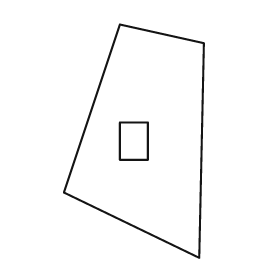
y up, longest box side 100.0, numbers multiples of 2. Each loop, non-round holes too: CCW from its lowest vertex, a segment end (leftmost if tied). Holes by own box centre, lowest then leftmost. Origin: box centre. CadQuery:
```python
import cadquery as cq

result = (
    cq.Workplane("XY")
    .moveTo(28.0, -50.0)
    .lineTo(30.0, 42.0)
    .lineTo(-6.0, 50.0)
    .lineTo(-30.0, -22.0)
    .close()
    .moveTo(-6.0, -8.0)
    .lineTo(6.0, -8.0)
    .lineTo(6.0, 8.0)
    .lineTo(-6.0, 8.0)
    .close()
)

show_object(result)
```